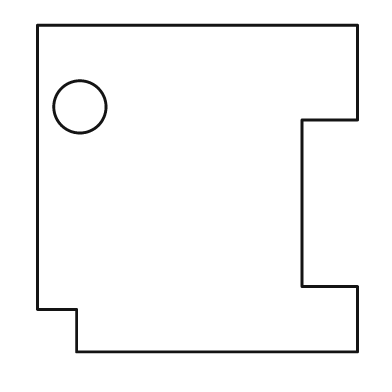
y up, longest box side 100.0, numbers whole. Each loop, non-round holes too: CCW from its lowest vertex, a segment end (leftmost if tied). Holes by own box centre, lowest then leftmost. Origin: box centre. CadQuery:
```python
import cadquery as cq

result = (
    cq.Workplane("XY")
    .moveTo(-37.0, -50.0)
    .lineTo(49.0, -50.0)
    .lineTo(49.0, -30.0)
    .lineTo(32.0, -30.0)
    .lineTo(32.0, 21.0)
    .lineTo(49.0, 21.0)
    .lineTo(49.0, 50.0)
    .lineTo(-49.0, 50.0)
    .lineTo(-49.0, -37.0)
    .lineTo(-37.0, -37.0)
    .close()
    .moveTo(-36.0, 25.0)
    .circle(8.0)
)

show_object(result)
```